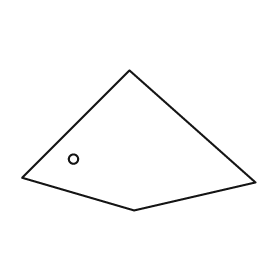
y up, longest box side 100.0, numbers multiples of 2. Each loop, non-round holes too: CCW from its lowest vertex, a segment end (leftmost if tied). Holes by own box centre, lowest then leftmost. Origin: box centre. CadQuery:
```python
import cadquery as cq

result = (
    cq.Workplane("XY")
    .moveTo(-2.0, -30.0)
    .lineTo(50.0, -18.0)
    .lineTo(-4.0, 30.0)
    .lineTo(-50.0, -16.0)
    .close()
    .moveTo(-28.0, -8.0)
    .circle(2.0)
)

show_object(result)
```